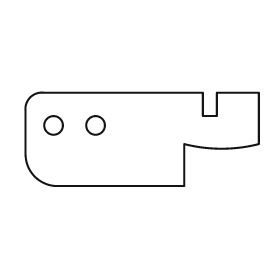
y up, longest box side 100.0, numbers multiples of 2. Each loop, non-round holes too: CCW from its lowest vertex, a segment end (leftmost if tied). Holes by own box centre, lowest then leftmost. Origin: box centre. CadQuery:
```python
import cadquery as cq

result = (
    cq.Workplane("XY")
    .moveTo(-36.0, -20.0)
    .lineTo(18.0, -20.0)
    .lineTo(18.0, -2.0)
    .threePointArc((34.0, -4.0), (50.0, -2.0))
    .lineTo(50.0, 20.0)
    .lineTo(32.0, 20.0)
    .lineTo(32.0, 10.0)
    .lineTo(26.0, 10.0)
    .lineTo(26.0, 20.0)
    .lineTo(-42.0, 20.0)
    .threePointArc((-48.0, 18.0), (-50.0, 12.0))
    .lineTo(-50.0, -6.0)
    .threePointArc((-46.0, -16.0), (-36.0, -20.0))
    .close()
    .moveTo(-38.0, 6.0)
    .circle(4.0)
    .moveTo(-20.0, 6.0)
    .circle(4.0)
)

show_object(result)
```